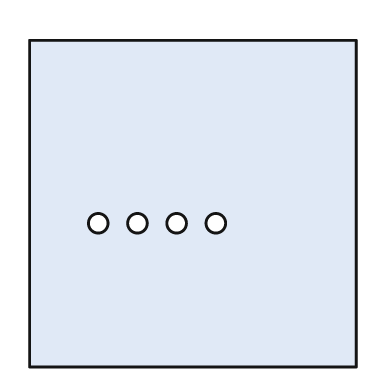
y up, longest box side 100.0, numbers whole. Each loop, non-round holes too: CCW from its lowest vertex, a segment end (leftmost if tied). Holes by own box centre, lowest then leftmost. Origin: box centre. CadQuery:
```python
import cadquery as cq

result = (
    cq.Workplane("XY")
    .moveTo(-50.0, -50.0)
    .lineTo(50.0, -50.0)
    .lineTo(50.0, 50.0)
    .lineTo(-50.0, 50.0)
    .close()
    .moveTo(-29.0, -6.0)
    .circle(3.0)
    .moveTo(-17.0, -6.0)
    .circle(3.0)
    .moveTo(-5.0, -6.0)
    .circle(3.0)
    .moveTo(7.0, -6.0)
    .circle(3.0)
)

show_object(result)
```